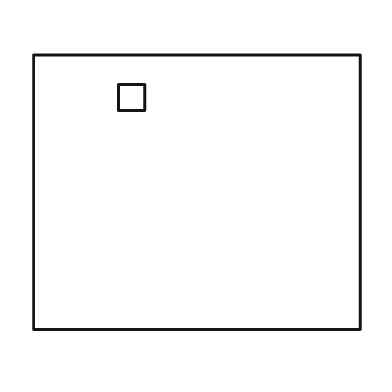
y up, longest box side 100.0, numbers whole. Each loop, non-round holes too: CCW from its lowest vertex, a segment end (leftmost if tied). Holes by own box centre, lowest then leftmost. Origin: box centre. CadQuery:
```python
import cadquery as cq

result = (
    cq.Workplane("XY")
    .moveTo(-50.0, -42.0)
    .lineTo(50.0, -42.0)
    .lineTo(50.0, 42.0)
    .lineTo(-50.0, 42.0)
    .close()
    .moveTo(-24.0, 25.0)
    .lineTo(-16.0, 25.0)
    .lineTo(-16.0, 33.0)
    .lineTo(-24.0, 33.0)
    .close()
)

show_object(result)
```